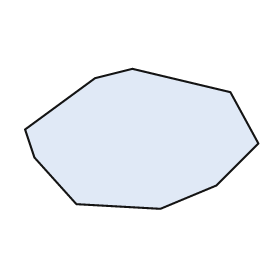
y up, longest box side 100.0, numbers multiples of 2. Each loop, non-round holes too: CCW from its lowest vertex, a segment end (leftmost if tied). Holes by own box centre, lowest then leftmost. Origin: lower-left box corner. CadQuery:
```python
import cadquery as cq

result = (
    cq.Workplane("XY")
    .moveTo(58.0, 0.0)
    .lineTo(82.0, 10.0)
    .lineTo(100.0, 28.0)
    .lineTo(88.0, 50.0)
    .lineTo(46.0, 60.0)
    .lineTo(30.0, 56.0)
    .lineTo(0.0, 34.0)
    .lineTo(4.0, 22.0)
    .lineTo(22.0, 2.0)
    .close()
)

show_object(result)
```